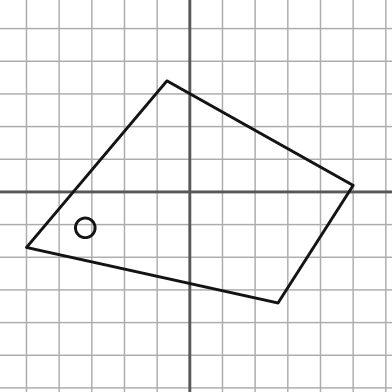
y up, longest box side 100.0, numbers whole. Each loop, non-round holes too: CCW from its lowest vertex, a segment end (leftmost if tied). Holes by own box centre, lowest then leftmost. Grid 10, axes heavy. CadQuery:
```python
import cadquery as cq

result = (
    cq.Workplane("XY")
    .moveTo(27.0, -34.0)
    .lineTo(50.0, 2.0)
    .lineTo(-7.0, 34.0)
    .lineTo(-50.0, -17.0)
    .close()
    .moveTo(-32.0, -11.0)
    .circle(3.0)
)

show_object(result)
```